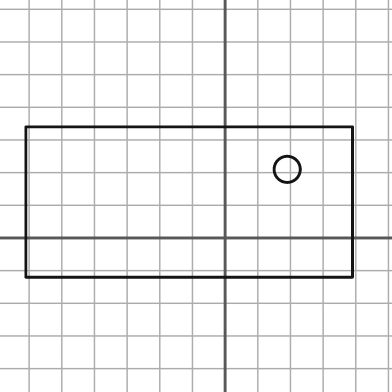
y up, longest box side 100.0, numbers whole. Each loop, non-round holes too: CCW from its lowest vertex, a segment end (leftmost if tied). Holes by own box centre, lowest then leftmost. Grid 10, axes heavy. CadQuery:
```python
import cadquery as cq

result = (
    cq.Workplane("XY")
    .moveTo(-61.0, -12.0)
    .lineTo(39.0, -12.0)
    .lineTo(39.0, 34.0)
    .lineTo(-61.0, 34.0)
    .close()
    .moveTo(19.0, 21.0)
    .circle(4.0)
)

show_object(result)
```